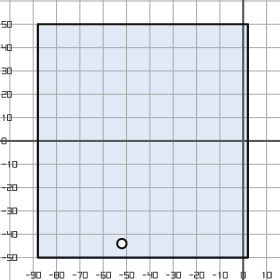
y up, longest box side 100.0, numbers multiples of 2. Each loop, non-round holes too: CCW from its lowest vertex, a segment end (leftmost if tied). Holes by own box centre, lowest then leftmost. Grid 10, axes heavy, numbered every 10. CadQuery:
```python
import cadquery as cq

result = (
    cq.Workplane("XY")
    .moveTo(-88.0, -50.0)
    .lineTo(2.0, -50.0)
    .lineTo(2.0, 50.0)
    .lineTo(-88.0, 50.0)
    .close()
    .moveTo(-52.0, -44.0)
    .circle(2.0)
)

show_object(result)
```